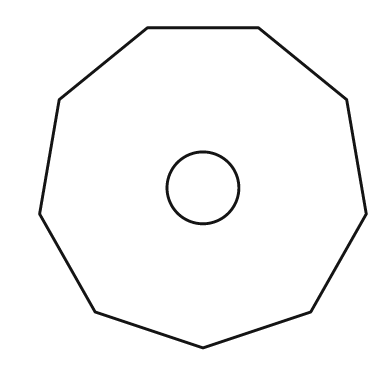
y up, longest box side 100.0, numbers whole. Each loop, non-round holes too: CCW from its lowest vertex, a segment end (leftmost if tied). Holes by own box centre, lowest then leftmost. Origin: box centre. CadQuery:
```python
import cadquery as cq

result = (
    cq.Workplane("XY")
    .moveTo(0.0, -49.0)
    .lineTo(33.0, -38.0)
    .lineTo(50.0, -8.0)
    .lineTo(44.0, 27.0)
    .lineTo(17.0, 49.0)
    .lineTo(-17.0, 49.0)
    .lineTo(-44.0, 27.0)
    .lineTo(-50.0, -8.0)
    .lineTo(-33.0, -38.0)
    .close()
    .moveTo(0.0, 0.0)
    .circle(11.0)
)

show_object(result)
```